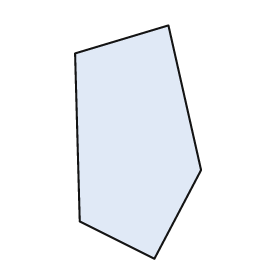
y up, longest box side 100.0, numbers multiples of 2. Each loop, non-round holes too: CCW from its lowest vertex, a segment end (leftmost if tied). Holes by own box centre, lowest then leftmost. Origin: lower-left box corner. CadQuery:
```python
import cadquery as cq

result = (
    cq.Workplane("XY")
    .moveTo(34.0, 0.0)
    .lineTo(54.0, 38.0)
    .lineTo(40.0, 100.0)
    .lineTo(0.0, 88.0)
    .lineTo(2.0, 16.0)
    .close()
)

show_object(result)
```